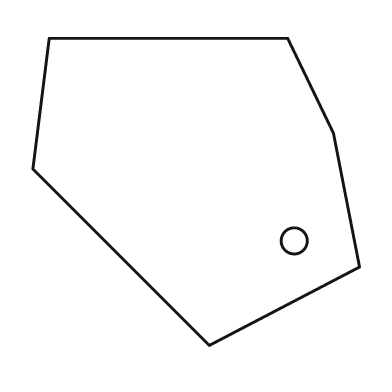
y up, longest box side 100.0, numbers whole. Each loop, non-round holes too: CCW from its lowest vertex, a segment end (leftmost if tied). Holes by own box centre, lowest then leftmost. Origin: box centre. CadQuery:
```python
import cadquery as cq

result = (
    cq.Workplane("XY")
    .moveTo(4.0, -47.0)
    .lineTo(50.0, -23.0)
    .lineTo(42.0, 18.0)
    .lineTo(28.0, 47.0)
    .lineTo(-45.0, 47.0)
    .lineTo(-50.0, 7.0)
    .close()
    .moveTo(30.0, -15.0)
    .circle(4.0)
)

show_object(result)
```